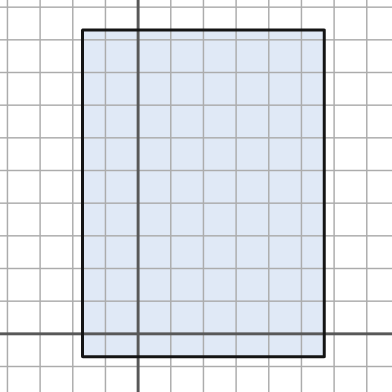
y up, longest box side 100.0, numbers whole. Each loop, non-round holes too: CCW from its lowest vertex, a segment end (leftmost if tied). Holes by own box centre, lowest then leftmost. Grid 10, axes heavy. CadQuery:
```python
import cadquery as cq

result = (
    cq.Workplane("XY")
    .moveTo(-17.0, -7.0)
    .lineTo(57.0, -7.0)
    .lineTo(57.0, 93.0)
    .lineTo(-17.0, 93.0)
    .close()
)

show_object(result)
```